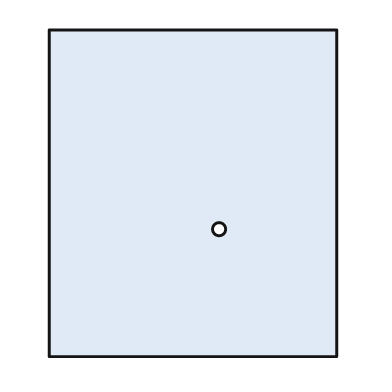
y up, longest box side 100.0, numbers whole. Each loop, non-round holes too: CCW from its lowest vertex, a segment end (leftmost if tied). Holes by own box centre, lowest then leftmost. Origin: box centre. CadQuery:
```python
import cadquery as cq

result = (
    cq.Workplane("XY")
    .moveTo(-44.0, -50.0)
    .lineTo(44.0, -50.0)
    .lineTo(44.0, 50.0)
    .lineTo(-44.0, 50.0)
    .close()
    .moveTo(8.0, -11.0)
    .circle(2.0)
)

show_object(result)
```